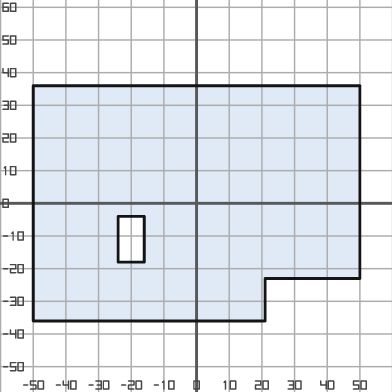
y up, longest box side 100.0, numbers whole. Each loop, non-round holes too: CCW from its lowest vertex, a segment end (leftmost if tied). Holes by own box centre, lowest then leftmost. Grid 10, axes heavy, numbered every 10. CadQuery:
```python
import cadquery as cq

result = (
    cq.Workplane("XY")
    .moveTo(-50.0, -36.0)
    .lineTo(21.0, -36.0)
    .lineTo(21.0, -23.0)
    .lineTo(50.0, -23.0)
    .lineTo(50.0, 36.0)
    .lineTo(-50.0, 36.0)
    .close()
    .moveTo(-24.0, -18.0)
    .lineTo(-16.0, -18.0)
    .lineTo(-16.0, -4.0)
    .lineTo(-24.0, -4.0)
    .close()
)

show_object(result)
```